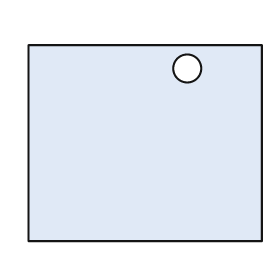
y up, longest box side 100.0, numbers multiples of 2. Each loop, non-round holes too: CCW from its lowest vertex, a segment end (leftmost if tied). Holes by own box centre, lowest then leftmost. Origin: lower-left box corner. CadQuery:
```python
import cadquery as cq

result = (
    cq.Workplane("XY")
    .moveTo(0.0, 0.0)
    .lineTo(100.0, 0.0)
    .lineTo(100.0, 84.0)
    .lineTo(0.0, 84.0)
    .close()
    .moveTo(68.0, 74.0)
    .circle(6.0)
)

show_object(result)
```